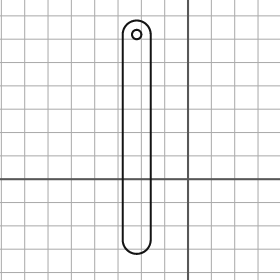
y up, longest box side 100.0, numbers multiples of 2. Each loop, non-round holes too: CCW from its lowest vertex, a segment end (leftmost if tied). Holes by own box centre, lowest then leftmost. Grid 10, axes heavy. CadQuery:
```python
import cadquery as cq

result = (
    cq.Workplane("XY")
    .moveTo(-28.0, -26.0)
    .threePointArc((-22.0, -32.0), (-16.0, -26.0))
    .lineTo(-16.0, 62.0)
    .threePointArc((-22.0, 68.0), (-28.0, 62.0))
    .close()
    .moveTo(-22.0, 62.0)
    .circle(2.0)
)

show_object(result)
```